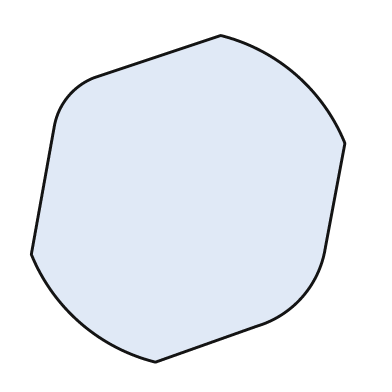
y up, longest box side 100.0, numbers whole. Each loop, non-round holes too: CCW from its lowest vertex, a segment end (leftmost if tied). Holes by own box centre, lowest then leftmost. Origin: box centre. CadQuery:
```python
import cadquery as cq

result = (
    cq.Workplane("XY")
    .moveTo(-10.0, -50.0)
    .lineTo(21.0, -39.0)
    .threePointArc((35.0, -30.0), (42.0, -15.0))
    .lineTo(48.0, 17.0)
    .threePointArc((33.0, 38.0), (10.0, 50.0))
    .lineTo(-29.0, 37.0)
    .threePointArc((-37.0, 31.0), (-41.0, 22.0))
    .lineTo(-48.0, -17.0)
    .threePointArc((-33.0, -38.0), (-10.0, -50.0))
    .close()
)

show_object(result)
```